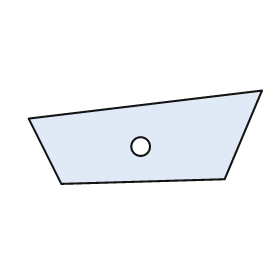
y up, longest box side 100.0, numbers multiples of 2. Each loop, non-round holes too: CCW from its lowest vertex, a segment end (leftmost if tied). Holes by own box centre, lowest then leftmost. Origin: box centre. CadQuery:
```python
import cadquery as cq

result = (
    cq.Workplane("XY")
    .moveTo(-36.0, -20.0)
    .lineTo(34.0, -18.0)
    .lineTo(50.0, 20.0)
    .lineTo(-50.0, 8.0)
    .close()
    .moveTo(-2.0, -4.0)
    .circle(4.0)
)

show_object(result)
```